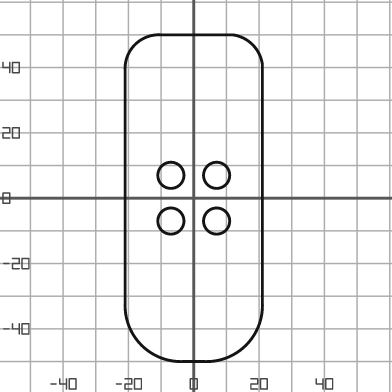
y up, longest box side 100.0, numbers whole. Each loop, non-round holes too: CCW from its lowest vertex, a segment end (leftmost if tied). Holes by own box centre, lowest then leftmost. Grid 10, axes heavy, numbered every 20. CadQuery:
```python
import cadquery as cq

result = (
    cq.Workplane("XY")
    .moveTo(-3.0, -50.0)
    .lineTo(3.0, -50.0)
    .threePointArc((16.0, -45.0), (21.0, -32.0))
    .lineTo(21.0, 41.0)
    .threePointArc((18.0, 47.0), (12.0, 50.0))
    .lineTo(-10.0, 50.0)
    .threePointArc((-18.0, 47.0), (-21.0, 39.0))
    .lineTo(-21.0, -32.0)
    .threePointArc((-16.0, -45.0), (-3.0, -50.0))
    .close()
    .moveTo(-7.0, -7.0)
    .circle(4.0)
    .moveTo(7.0, -7.0)
    .circle(4.0)
    .moveTo(-7.0, 7.0)
    .circle(4.0)
    .moveTo(7.0, 7.0)
    .circle(4.0)
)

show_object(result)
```